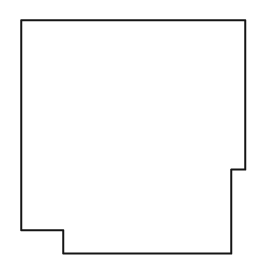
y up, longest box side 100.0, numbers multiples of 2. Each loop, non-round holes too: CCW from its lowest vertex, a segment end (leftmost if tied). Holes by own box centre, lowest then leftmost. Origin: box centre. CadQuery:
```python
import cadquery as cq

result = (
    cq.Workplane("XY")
    .moveTo(-30.0, -50.0)
    .lineTo(42.0, -50.0)
    .lineTo(42.0, -14.0)
    .lineTo(48.0, -14.0)
    .lineTo(48.0, 50.0)
    .lineTo(-48.0, 50.0)
    .lineTo(-48.0, -40.0)
    .lineTo(-30.0, -40.0)
    .close()
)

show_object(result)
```